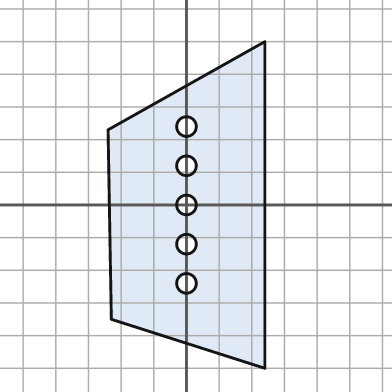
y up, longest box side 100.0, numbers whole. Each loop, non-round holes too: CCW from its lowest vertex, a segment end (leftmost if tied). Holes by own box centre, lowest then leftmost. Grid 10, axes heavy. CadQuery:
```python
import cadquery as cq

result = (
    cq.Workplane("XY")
    .moveTo(24.0, -50.0)
    .lineTo(24.0, 50.0)
    .lineTo(-24.0, 23.0)
    .lineTo(-23.0, -35.0)
    .close()
    .moveTo(0.0, -24.0)
    .circle(3.0)
    .moveTo(0.0, -12.0)
    .circle(3.0)
    .moveTo(0.0, 0.0)
    .circle(3.0)
    .moveTo(0.0, 12.0)
    .circle(3.0)
    .moveTo(0.0, 24.0)
    .circle(3.0)
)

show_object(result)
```